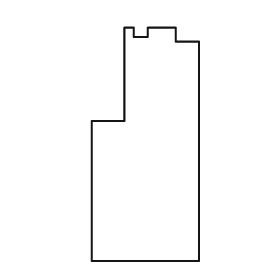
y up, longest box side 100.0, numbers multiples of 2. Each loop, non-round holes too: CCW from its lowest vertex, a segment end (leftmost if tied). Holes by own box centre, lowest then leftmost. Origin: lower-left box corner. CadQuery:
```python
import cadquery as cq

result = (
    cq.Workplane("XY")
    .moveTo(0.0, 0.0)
    .lineTo(46.0, 0.0)
    .lineTo(46.0, 94.0)
    .lineTo(36.0, 94.0)
    .lineTo(36.0, 100.0)
    .lineTo(24.0, 100.0)
    .lineTo(24.0, 96.0)
    .lineTo(18.0, 96.0)
    .lineTo(18.0, 100.0)
    .lineTo(14.0, 100.0)
    .lineTo(14.0, 60.0)
    .lineTo(0.0, 60.0)
    .close()
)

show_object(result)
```